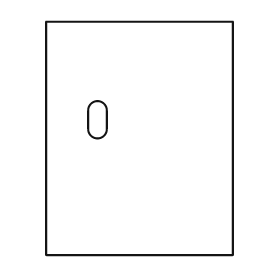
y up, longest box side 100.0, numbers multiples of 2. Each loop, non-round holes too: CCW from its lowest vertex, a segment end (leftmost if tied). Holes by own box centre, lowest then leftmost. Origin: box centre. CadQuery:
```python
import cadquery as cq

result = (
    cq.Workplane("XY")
    .moveTo(-40.0, -50.0)
    .lineTo(40.0, -50.0)
    .lineTo(40.0, 50.0)
    .lineTo(-40.0, 50.0)
    .close()
    .moveTo(-22.0, 4.0)
    .threePointArc((-18.0, 0.0), (-14.0, 4.0))
    .lineTo(-14.0, 12.0)
    .threePointArc((-18.0, 16.0), (-22.0, 12.0))
    .close()
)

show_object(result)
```